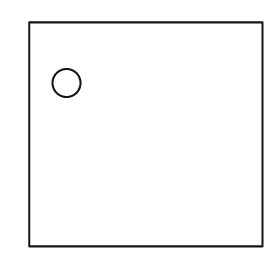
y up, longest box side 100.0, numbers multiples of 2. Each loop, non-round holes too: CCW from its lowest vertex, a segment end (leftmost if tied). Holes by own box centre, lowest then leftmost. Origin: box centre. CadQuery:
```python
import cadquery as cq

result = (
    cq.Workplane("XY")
    .moveTo(-50.0, -48.0)
    .lineTo(50.0, -48.0)
    .lineTo(50.0, 48.0)
    .lineTo(-50.0, 48.0)
    .close()
    .moveTo(-34.0, 22.0)
    .circle(6.0)
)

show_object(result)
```